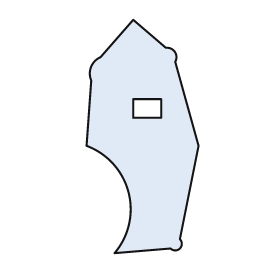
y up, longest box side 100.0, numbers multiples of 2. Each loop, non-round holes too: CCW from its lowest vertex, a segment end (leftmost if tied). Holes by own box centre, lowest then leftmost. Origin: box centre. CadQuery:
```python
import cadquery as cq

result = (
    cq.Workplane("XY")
    .moveTo(-12.0, -50.0)
    .lineTo(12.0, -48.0)
    .threePointArc((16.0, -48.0), (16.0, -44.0))
    .lineTo(24.0, -4.0)
    .lineTo(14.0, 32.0)
    .threePointArc((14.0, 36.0), (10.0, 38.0))
    .lineTo(-4.0, 50.0)
    .lineTo(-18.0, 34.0)
    .threePointArc((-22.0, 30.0), (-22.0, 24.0))
    .lineTo(-24.0, -4.0)
    .threePointArc((-6.0, -24.0), (-12.0, -50.0))
    .close()
    .moveTo(-4.0, 8.0)
    .lineTo(8.0, 8.0)
    .lineTo(8.0, 16.0)
    .lineTo(-4.0, 16.0)
    .close()
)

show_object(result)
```